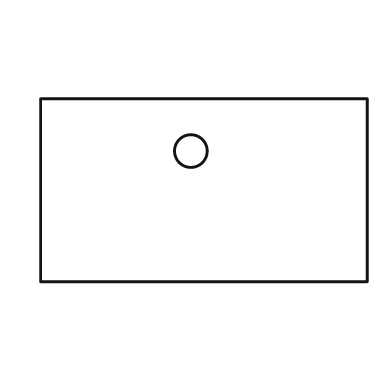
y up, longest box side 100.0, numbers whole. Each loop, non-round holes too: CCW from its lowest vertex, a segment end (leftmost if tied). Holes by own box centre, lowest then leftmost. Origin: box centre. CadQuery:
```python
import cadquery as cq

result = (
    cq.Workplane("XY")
    .moveTo(-50.0, -28.0)
    .lineTo(50.0, -28.0)
    .lineTo(50.0, 28.0)
    .lineTo(-50.0, 28.0)
    .close()
    .moveTo(-4.0, 12.0)
    .circle(5.0)
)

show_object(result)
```